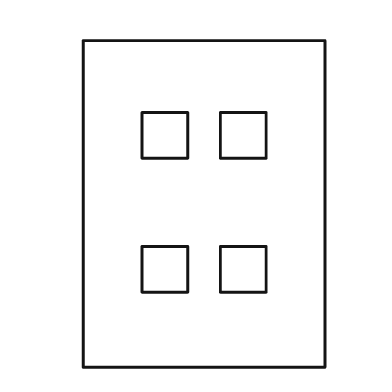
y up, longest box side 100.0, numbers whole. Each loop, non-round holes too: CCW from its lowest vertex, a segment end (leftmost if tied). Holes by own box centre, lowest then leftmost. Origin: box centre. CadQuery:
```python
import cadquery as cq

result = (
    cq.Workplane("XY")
    .moveTo(-37.0, -50.0)
    .lineTo(37.0, -50.0)
    .lineTo(37.0, 50.0)
    .lineTo(-37.0, 50.0)
    .close()
    .moveTo(-19.0, -27.0)
    .lineTo(-5.0, -27.0)
    .lineTo(-5.0, -13.0)
    .lineTo(-19.0, -13.0)
    .close()
    .moveTo(5.0, -27.0)
    .lineTo(19.0, -27.0)
    .lineTo(19.0, -13.0)
    .lineTo(5.0, -13.0)
    .close()
    .moveTo(-19.0, 14.0)
    .lineTo(-5.0, 14.0)
    .lineTo(-5.0, 28.0)
    .lineTo(-19.0, 28.0)
    .close()
    .moveTo(5.0, 14.0)
    .lineTo(19.0, 14.0)
    .lineTo(19.0, 28.0)
    .lineTo(5.0, 28.0)
    .close()
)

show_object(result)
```